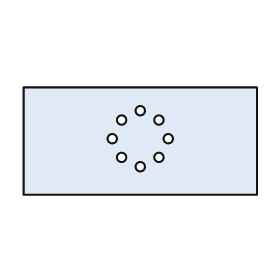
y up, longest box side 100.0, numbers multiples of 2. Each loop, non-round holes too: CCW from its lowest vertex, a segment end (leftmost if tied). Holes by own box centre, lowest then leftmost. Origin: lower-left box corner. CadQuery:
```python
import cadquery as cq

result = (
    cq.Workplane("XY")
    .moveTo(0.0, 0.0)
    .lineTo(100.0, 0.0)
    .lineTo(100.0, 46.0)
    .lineTo(0.0, 46.0)
    .close()
    .moveTo(50.0, 12.0)
    .circle(2.0)
    .moveTo(42.0, 16.0)
    .circle(2.0)
    .moveTo(58.0, 16.0)
    .circle(2.0)
    .moveTo(38.0, 24.0)
    .circle(2.0)
    .moveTo(62.0, 24.0)
    .circle(2.0)
    .moveTo(42.0, 32.0)
    .circle(2.0)
    .moveTo(58.0, 32.0)
    .circle(2.0)
    .moveTo(50.0, 36.0)
    .circle(2.0)
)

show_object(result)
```